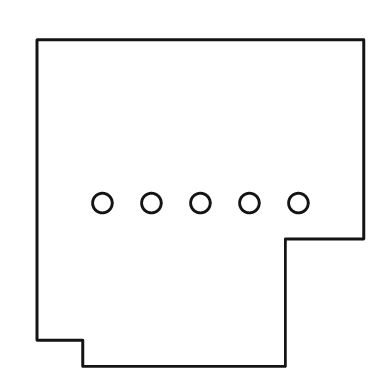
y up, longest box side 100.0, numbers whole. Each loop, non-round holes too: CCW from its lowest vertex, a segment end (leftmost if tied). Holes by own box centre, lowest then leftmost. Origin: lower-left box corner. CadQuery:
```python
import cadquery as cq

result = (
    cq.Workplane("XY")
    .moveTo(14.0, 0.0)
    .lineTo(76.0, 0.0)
    .lineTo(76.0, 39.0)
    .lineTo(100.0, 39.0)
    .lineTo(100.0, 100.0)
    .lineTo(0.0, 100.0)
    .lineTo(0.0, 8.0)
    .lineTo(14.0, 8.0)
    .close()
    .moveTo(20.0, 50.0)
    .circle(3.0)
    .moveTo(35.0, 50.0)
    .circle(3.0)
    .moveTo(50.0, 50.0)
    .circle(3.0)
    .moveTo(65.0, 50.0)
    .circle(3.0)
    .moveTo(80.0, 50.0)
    .circle(3.0)
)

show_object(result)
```